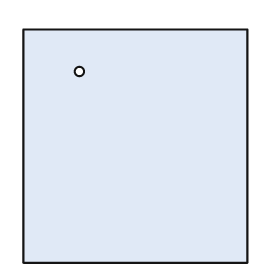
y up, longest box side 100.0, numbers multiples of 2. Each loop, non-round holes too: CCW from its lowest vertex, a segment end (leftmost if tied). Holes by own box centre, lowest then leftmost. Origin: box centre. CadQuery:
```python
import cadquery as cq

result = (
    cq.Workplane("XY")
    .moveTo(-48.0, -50.0)
    .lineTo(48.0, -50.0)
    .lineTo(48.0, 50.0)
    .lineTo(-48.0, 50.0)
    .close()
    .moveTo(-24.0, 32.0)
    .circle(2.0)
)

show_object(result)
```